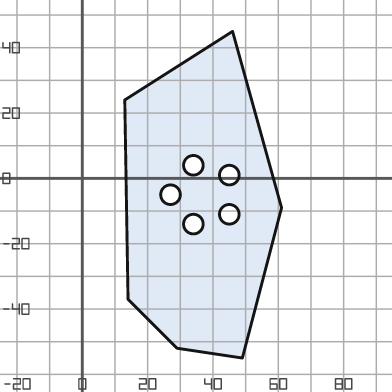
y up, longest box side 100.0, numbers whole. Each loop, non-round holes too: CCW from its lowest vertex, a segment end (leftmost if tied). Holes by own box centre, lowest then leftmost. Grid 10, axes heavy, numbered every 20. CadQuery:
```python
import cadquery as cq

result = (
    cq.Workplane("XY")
    .moveTo(49.0, -55.0)
    .lineTo(61.0, -9.0)
    .lineTo(46.0, 45.0)
    .lineTo(13.0, 24.0)
    .lineTo(14.0, -37.0)
    .lineTo(29.0, -52.0)
    .close()
    .moveTo(34.0, -14.0)
    .circle(3.0)
    .moveTo(45.0, -11.0)
    .circle(3.0)
    .moveTo(27.0, -5.0)
    .circle(3.0)
    .moveTo(45.0, 1.0)
    .circle(3.0)
    .moveTo(34.0, 4.0)
    .circle(3.0)
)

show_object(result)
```